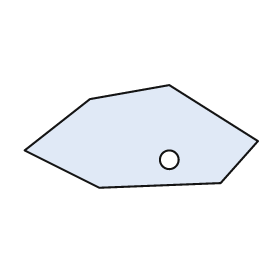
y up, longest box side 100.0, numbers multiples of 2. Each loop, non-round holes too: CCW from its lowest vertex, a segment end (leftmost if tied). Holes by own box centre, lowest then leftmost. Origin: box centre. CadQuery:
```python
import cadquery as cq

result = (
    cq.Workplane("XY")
    .moveTo(-18.0, -22.0)
    .lineTo(34.0, -20.0)
    .lineTo(50.0, -2.0)
    .lineTo(12.0, 22.0)
    .lineTo(-22.0, 16.0)
    .lineTo(-50.0, -6.0)
    .close()
    .moveTo(12.0, -10.0)
    .circle(4.0)
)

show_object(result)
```